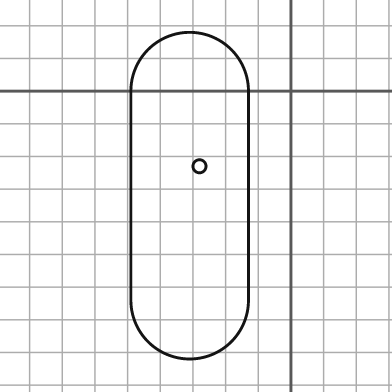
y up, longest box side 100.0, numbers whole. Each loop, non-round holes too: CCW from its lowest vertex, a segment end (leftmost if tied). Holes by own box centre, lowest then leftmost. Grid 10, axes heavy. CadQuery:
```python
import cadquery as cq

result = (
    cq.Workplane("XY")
    .moveTo(-49.0, -64.0)
    .threePointArc((-31.0, -82.0), (-13.0, -64.0))
    .lineTo(-13.0, 0.0)
    .threePointArc((-31.0, 18.0), (-49.0, 0.0))
    .close()
    .moveTo(-28.0, -23.0)
    .circle(2.0)
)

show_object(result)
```